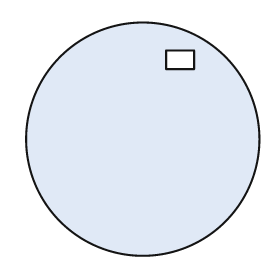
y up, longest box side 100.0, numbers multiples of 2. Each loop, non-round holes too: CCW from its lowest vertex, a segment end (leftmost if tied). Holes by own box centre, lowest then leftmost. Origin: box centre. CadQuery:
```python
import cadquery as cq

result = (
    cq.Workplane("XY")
    .moveTo(0.0, 0.0)
    .circle(50.0)
    .moveTo(10.0, 30.0)
    .lineTo(22.0, 30.0)
    .lineTo(22.0, 38.0)
    .lineTo(10.0, 38.0)
    .close()
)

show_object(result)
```